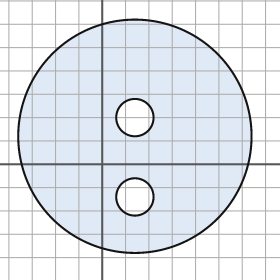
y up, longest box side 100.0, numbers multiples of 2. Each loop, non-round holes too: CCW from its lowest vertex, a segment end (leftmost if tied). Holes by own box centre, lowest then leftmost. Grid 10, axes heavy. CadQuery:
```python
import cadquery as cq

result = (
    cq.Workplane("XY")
    .moveTo(14.0, 12.0)
    .circle(50.0)
    .moveTo(14.0, -14.0)
    .circle(8.0)
    .moveTo(14.0, 20.0)
    .circle(8.0)
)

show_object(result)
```